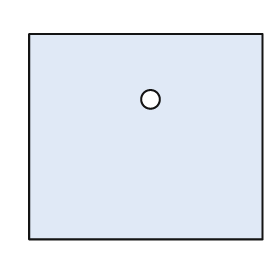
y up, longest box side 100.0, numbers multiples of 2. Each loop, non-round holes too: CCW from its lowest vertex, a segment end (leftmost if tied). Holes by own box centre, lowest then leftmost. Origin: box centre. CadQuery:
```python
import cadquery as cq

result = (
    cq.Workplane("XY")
    .moveTo(-50.0, -44.0)
    .lineTo(50.0, -44.0)
    .lineTo(50.0, 44.0)
    .lineTo(-50.0, 44.0)
    .close()
    .moveTo(2.0, 16.0)
    .circle(4.0)
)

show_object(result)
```